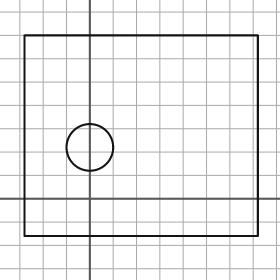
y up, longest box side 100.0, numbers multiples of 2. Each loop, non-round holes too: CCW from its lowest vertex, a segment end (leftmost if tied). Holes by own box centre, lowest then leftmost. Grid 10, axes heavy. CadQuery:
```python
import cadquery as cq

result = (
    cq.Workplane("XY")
    .moveTo(-28.0, -16.0)
    .lineTo(72.0, -16.0)
    .lineTo(72.0, 70.0)
    .lineTo(-28.0, 70.0)
    .close()
    .moveTo(0.0, 22.0)
    .circle(10.0)
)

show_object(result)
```